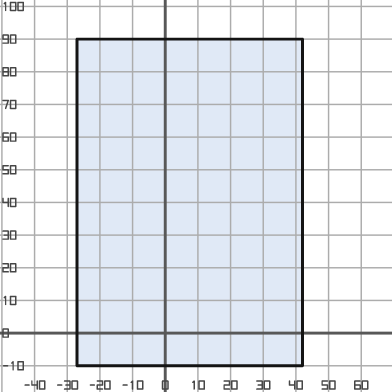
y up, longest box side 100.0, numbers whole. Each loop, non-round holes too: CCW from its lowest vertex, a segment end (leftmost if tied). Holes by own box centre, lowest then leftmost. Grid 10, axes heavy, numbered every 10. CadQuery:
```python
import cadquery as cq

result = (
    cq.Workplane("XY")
    .moveTo(-27.0, -10.0)
    .lineTo(42.0, -10.0)
    .lineTo(42.0, 90.0)
    .lineTo(-27.0, 90.0)
    .close()
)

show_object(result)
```